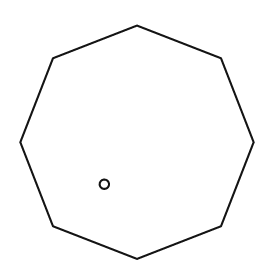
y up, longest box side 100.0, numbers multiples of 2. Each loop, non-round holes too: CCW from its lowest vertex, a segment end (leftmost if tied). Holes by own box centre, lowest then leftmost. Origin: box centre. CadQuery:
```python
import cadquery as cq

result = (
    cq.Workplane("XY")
    .moveTo(0.0, -50.0)
    .lineTo(36.0, -36.0)
    .lineTo(50.0, 0.0)
    .lineTo(36.0, 36.0)
    .lineTo(0.0, 50.0)
    .lineTo(-36.0, 36.0)
    .lineTo(-50.0, 0.0)
    .lineTo(-36.0, -36.0)
    .close()
    .moveTo(-14.0, -18.0)
    .circle(2.0)
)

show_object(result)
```